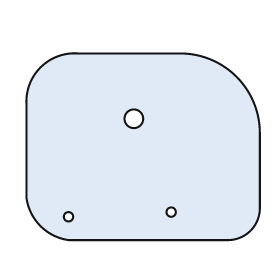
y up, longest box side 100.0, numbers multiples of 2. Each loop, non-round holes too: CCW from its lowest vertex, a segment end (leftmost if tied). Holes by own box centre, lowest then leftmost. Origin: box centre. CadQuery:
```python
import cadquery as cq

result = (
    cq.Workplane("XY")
    .moveTo(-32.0, -40.0)
    .lineTo(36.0, -40.0)
    .threePointArc((46.0, -36.0), (50.0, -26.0))
    .lineTo(50.0, 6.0)
    .threePointArc((40.0, 30.0), (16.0, 40.0))
    .lineTo(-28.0, 40.0)
    .threePointArc((-44.0, 34.0), (-50.0, 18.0))
    .lineTo(-50.0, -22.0)
    .threePointArc((-44.0, -34.0), (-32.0, -40.0))
    .close()
    .moveTo(-32.0, -30.0)
    .circle(2.0)
    .moveTo(12.0, -28.0)
    .circle(2.0)
    .moveTo(-4.0, 12.0)
    .circle(4.0)
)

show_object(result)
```